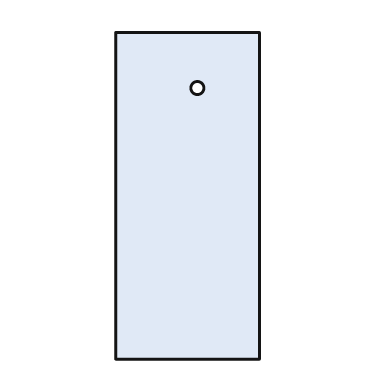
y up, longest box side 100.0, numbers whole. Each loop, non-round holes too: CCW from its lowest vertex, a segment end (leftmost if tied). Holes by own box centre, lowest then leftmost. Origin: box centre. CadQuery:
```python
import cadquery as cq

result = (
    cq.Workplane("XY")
    .moveTo(-22.0, -50.0)
    .lineTo(22.0, -50.0)
    .lineTo(22.0, 50.0)
    .lineTo(-22.0, 50.0)
    .close()
    .moveTo(3.0, 33.0)
    .circle(2.0)
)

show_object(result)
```